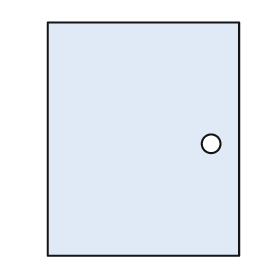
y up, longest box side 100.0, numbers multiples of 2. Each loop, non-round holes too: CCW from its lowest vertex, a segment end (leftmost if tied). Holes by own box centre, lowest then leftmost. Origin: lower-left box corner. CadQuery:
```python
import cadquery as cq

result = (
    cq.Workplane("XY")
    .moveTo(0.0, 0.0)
    .lineTo(82.0, 0.0)
    .lineTo(82.0, 100.0)
    .lineTo(0.0, 100.0)
    .close()
    .moveTo(70.0, 48.0)
    .circle(4.0)
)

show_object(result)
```